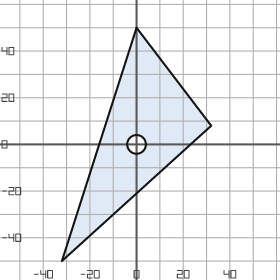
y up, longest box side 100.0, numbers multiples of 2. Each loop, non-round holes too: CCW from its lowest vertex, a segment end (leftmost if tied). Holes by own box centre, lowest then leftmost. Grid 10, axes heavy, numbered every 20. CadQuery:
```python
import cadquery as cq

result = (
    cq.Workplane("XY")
    .moveTo(-32.0, -50.0)
    .lineTo(32.0, 8.0)
    .lineTo(0.0, 50.0)
    .close()
    .moveTo(0.0, 0.0)
    .circle(4.0)
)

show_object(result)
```